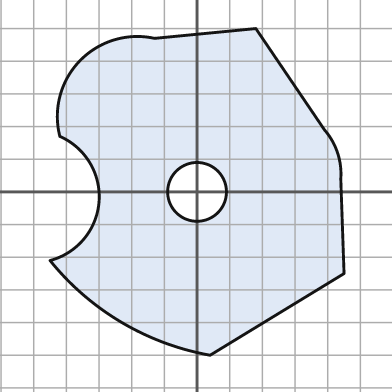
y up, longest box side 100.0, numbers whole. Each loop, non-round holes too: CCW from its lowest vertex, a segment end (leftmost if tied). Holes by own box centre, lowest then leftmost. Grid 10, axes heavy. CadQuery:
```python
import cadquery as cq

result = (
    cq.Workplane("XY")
    .moveTo(4.0, -50.0)
    .lineTo(45.0, -25.0)
    .lineTo(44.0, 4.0)
    .threePointArc((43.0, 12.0), (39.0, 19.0))
    .lineTo(18.0, 50.0)
    .lineTo(-13.0, 47.0)
    .threePointArc((-36.0, 40.0), (-42.0, 17.0))
    .threePointArc((-30.0, -3.0), (-45.0, -21.0))
    .threePointArc((-23.0, -40.0), (4.0, -50.0))
    .close()
    .moveTo(0.0, 0.0)
    .circle(9.0)
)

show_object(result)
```